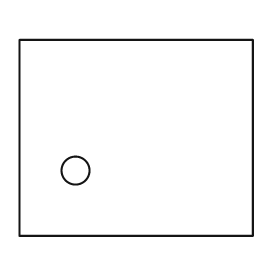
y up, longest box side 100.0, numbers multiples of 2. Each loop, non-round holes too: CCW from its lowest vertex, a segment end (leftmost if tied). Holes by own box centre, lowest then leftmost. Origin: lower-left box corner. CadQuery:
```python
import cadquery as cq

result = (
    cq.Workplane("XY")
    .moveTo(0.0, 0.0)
    .lineTo(100.0, 0.0)
    .lineTo(100.0, 84.0)
    .lineTo(0.0, 84.0)
    .close()
    .moveTo(24.0, 28.0)
    .circle(6.0)
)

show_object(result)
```